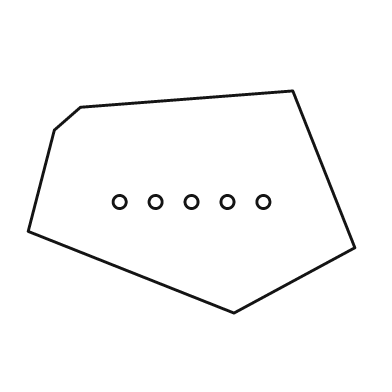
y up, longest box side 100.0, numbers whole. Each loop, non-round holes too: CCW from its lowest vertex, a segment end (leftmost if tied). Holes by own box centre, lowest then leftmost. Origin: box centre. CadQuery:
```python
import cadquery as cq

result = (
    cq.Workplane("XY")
    .moveTo(13.0, -34.0)
    .lineTo(50.0, -14.0)
    .lineTo(31.0, 34.0)
    .lineTo(-34.0, 29.0)
    .lineTo(-42.0, 22.0)
    .lineTo(-50.0, -9.0)
    .close()
    .moveTo(-22.0, 0.0)
    .circle(2.0)
    .moveTo(-11.0, 0.0)
    .circle(2.0)
    .moveTo(0.0, 0.0)
    .circle(2.0)
    .moveTo(11.0, 0.0)
    .circle(2.0)
    .moveTo(22.0, 0.0)
    .circle(2.0)
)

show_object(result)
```